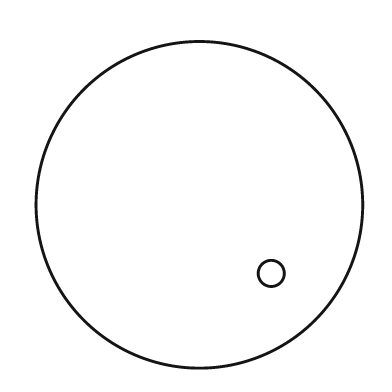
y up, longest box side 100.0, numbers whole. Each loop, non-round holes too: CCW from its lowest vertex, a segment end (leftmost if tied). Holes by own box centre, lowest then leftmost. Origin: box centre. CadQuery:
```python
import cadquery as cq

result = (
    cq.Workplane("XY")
    .moveTo(0.0, 0.0)
    .circle(50.0)
    .moveTo(22.0, -21.0)
    .circle(4.0)
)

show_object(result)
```